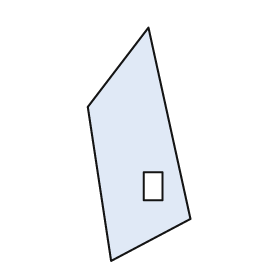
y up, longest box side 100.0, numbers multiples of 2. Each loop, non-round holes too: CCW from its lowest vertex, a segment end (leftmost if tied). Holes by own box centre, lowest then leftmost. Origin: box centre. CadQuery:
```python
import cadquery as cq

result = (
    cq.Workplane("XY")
    .moveTo(-12.0, -50.0)
    .lineTo(22.0, -32.0)
    .lineTo(4.0, 50.0)
    .lineTo(-22.0, 16.0)
    .close()
    .moveTo(2.0, -24.0)
    .lineTo(10.0, -24.0)
    .lineTo(10.0, -12.0)
    .lineTo(2.0, -12.0)
    .close()
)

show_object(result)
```